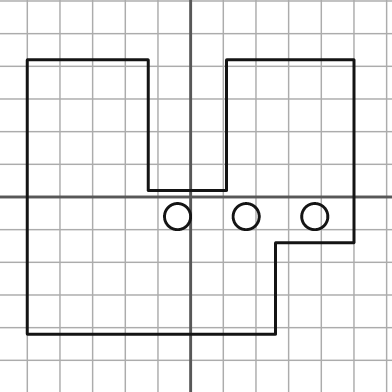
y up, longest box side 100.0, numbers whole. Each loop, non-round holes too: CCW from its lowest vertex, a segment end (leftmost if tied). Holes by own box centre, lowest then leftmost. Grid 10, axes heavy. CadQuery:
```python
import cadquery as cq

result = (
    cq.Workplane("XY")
    .moveTo(-50.0, -42.0)
    .lineTo(26.0, -42.0)
    .lineTo(26.0, -14.0)
    .lineTo(50.0, -14.0)
    .lineTo(50.0, 42.0)
    .lineTo(11.0, 42.0)
    .lineTo(11.0, 2.0)
    .lineTo(-13.0, 2.0)
    .lineTo(-13.0, 42.0)
    .lineTo(-50.0, 42.0)
    .close()
    .moveTo(-4.0, -6.0)
    .circle(4.0)
    .moveTo(17.0, -6.0)
    .circle(4.0)
    .moveTo(38.0, -6.0)
    .circle(4.0)
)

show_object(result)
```